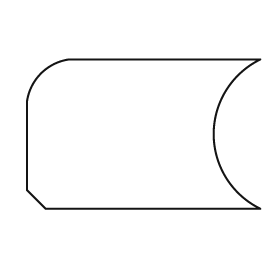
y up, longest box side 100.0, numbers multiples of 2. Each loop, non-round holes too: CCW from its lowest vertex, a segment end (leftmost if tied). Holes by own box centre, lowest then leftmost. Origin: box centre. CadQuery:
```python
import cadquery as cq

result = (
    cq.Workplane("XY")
    .moveTo(-42.0, -32.0)
    .lineTo(50.0, -32.0)
    .threePointArc((30.0, 0.0), (50.0, 32.0))
    .lineTo(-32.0, 32.0)
    .threePointArc((-44.0, 26.0), (-50.0, 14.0))
    .lineTo(-50.0, -24.0)
    .close()
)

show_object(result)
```